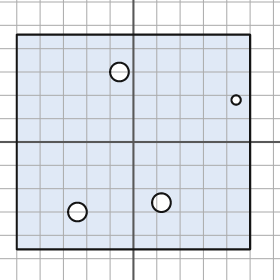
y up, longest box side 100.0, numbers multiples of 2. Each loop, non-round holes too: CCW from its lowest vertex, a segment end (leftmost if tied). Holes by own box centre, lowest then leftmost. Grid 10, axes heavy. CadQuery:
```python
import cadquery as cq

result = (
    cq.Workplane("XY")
    .moveTo(-50.0, -46.0)
    .lineTo(50.0, -46.0)
    .lineTo(50.0, 46.0)
    .lineTo(-50.0, 46.0)
    .close()
    .moveTo(-24.0, -30.0)
    .circle(4.0)
    .moveTo(12.0, -26.0)
    .circle(4.0)
    .moveTo(44.0, 18.0)
    .circle(2.0)
    .moveTo(-6.0, 30.0)
    .circle(4.0)
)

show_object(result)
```